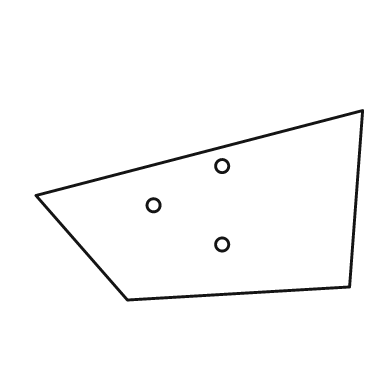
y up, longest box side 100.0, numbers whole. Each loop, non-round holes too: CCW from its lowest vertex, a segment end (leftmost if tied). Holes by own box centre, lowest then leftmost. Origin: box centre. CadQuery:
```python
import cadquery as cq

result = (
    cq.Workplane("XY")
    .moveTo(-22.0, -29.0)
    .lineTo(46.0, -25.0)
    .lineTo(50.0, 29.0)
    .lineTo(-50.0, 3.0)
    .close()
    .moveTo(7.0, -12.0)
    .circle(2.0)
    .moveTo(-14.0, 0.0)
    .circle(2.0)
    .moveTo(7.0, 12.0)
    .circle(2.0)
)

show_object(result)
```